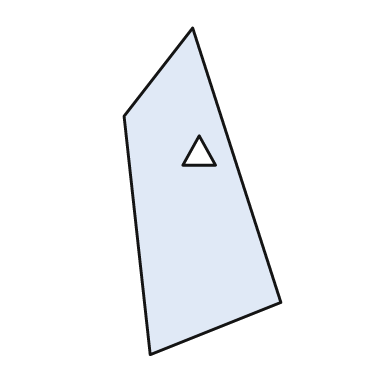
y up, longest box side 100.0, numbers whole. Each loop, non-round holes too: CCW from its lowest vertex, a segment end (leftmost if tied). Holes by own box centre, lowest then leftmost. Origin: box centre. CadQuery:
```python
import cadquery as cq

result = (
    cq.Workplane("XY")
    .moveTo(-16.0, -50.0)
    .lineTo(24.0, -34.0)
    .lineTo(-3.0, 50.0)
    .lineTo(-24.0, 23.0)
    .close()
    .moveTo(-6.0, 8.0)
    .lineTo(4.0, 8.0)
    .lineTo(-1.0, 17.0)
    .close()
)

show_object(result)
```